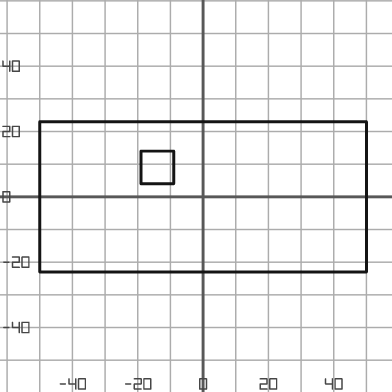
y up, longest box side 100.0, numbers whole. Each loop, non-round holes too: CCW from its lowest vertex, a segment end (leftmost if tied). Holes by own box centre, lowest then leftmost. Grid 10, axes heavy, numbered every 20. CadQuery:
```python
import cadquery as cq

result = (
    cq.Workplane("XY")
    .moveTo(-50.0, -23.0)
    .lineTo(50.0, -23.0)
    .lineTo(50.0, 23.0)
    .lineTo(-50.0, 23.0)
    .close()
    .moveTo(-19.0, 4.0)
    .lineTo(-9.0, 4.0)
    .lineTo(-9.0, 14.0)
    .lineTo(-19.0, 14.0)
    .close()
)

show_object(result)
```